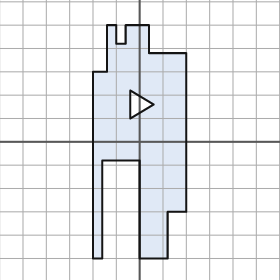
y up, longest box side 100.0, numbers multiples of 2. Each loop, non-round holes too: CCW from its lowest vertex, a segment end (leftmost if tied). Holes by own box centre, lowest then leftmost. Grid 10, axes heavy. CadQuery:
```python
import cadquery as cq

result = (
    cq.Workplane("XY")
    .moveTo(-20.0, -50.0)
    .lineTo(-16.0, -50.0)
    .lineTo(-16.0, -8.0)
    .lineTo(0.0, -8.0)
    .lineTo(0.0, -50.0)
    .lineTo(12.0, -50.0)
    .lineTo(12.0, -30.0)
    .lineTo(20.0, -30.0)
    .lineTo(20.0, 38.0)
    .lineTo(4.0, 38.0)
    .lineTo(4.0, 50.0)
    .lineTo(-6.0, 50.0)
    .lineTo(-6.0, 42.0)
    .lineTo(-10.0, 42.0)
    .lineTo(-10.0, 50.0)
    .lineTo(-14.0, 50.0)
    .lineTo(-14.0, 30.0)
    .lineTo(-20.0, 30.0)
    .close()
    .moveTo(-4.0, 10.0)
    .lineTo(6.0, 16.0)
    .lineTo(-4.0, 22.0)
    .close()
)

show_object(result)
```